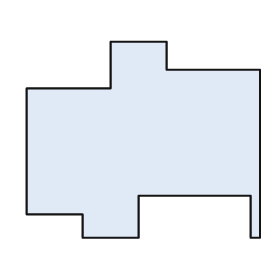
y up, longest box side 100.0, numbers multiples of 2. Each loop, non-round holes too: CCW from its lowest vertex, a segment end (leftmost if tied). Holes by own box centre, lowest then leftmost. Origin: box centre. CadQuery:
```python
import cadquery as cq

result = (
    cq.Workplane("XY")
    .moveTo(-26.0, -42.0)
    .lineTo(-2.0, -42.0)
    .lineTo(-2.0, -24.0)
    .lineTo(46.0, -24.0)
    .lineTo(46.0, -42.0)
    .lineTo(50.0, -42.0)
    .lineTo(50.0, 30.0)
    .lineTo(10.0, 30.0)
    .lineTo(10.0, 42.0)
    .lineTo(-14.0, 42.0)
    .lineTo(-14.0, 22.0)
    .lineTo(-50.0, 22.0)
    .lineTo(-50.0, -32.0)
    .lineTo(-26.0, -32.0)
    .close()
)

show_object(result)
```